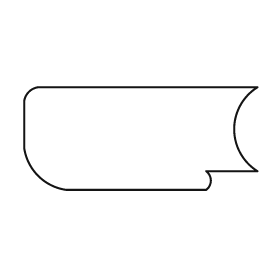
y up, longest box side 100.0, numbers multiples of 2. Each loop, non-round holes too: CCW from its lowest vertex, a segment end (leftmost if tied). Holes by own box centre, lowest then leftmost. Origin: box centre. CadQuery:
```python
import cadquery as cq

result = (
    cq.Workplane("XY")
    .moveTo(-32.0, -22.0)
    .lineTo(28.0, -22.0)
    .threePointArc((30.0, -18.0), (28.0, -14.0))
    .lineTo(50.0, -14.0)
    .threePointArc((40.0, 4.0), (50.0, 22.0))
    .lineTo(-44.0, 22.0)
    .threePointArc((-48.0, 20.0), (-50.0, 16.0))
    .lineTo(-50.0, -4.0)
    .threePointArc((-44.0, -16.0), (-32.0, -22.0))
    .close()
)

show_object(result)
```